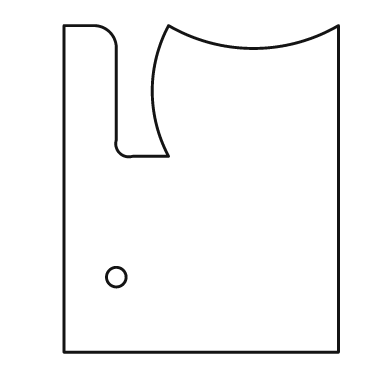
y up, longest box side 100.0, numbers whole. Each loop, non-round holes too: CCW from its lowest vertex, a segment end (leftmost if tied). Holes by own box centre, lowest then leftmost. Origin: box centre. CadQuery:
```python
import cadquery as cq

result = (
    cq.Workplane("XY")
    .moveTo(-42.0, -50.0)
    .lineTo(42.0, -50.0)
    .lineTo(42.0, 50.0)
    .threePointArc((16.0, 43.0), (-10.0, 50.0))
    .threePointArc((-15.0, 30.0), (-10.0, 10.0))
    .lineTo(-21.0, 10.0)
    .threePointArc((-25.0, 11.0), (-26.0, 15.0))
    .lineTo(-26.0, 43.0)
    .threePointArc((-28.0, 48.0), (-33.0, 50.0))
    .lineTo(-42.0, 50.0)
    .close()
    .moveTo(-26.0, -27.0)
    .circle(3.0)
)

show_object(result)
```